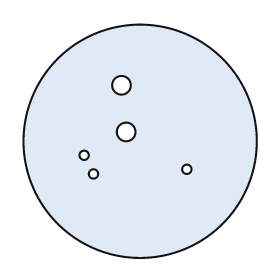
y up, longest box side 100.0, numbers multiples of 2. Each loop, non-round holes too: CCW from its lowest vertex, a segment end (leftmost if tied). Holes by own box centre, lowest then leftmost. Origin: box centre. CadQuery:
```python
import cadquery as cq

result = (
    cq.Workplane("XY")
    .moveTo(0.0, 0.0)
    .circle(50.0)
    .moveTo(-20.0, -14.0)
    .circle(2.0)
    .moveTo(20.0, -12.0)
    .circle(2.0)
    .moveTo(-24.0, -6.0)
    .circle(2.0)
    .moveTo(-6.0, 4.0)
    .circle(4.0)
    .moveTo(-8.0, 24.0)
    .circle(4.0)
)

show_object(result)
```